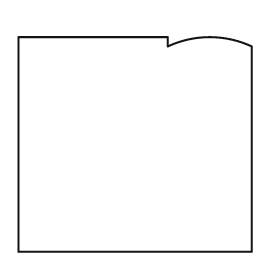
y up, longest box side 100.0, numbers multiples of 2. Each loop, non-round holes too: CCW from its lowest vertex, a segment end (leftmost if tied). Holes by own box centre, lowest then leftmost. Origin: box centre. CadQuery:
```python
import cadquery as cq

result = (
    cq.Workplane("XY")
    .moveTo(-50.0, -46.0)
    .lineTo(50.0, -46.0)
    .lineTo(50.0, 42.0)
    .threePointArc((32.0, 46.0), (14.0, 42.0))
    .lineTo(14.0, 46.0)
    .lineTo(-50.0, 46.0)
    .close()
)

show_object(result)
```